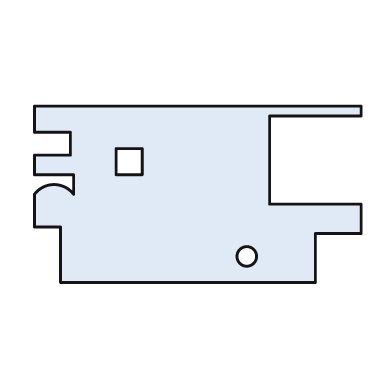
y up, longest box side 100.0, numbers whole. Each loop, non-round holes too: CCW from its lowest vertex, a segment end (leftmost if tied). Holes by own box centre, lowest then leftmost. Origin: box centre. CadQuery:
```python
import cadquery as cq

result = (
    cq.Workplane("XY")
    .moveTo(-42.0, -27.0)
    .lineTo(36.0, -27.0)
    .lineTo(36.0, -12.0)
    .lineTo(50.0, -12.0)
    .lineTo(50.0, -3.0)
    .lineTo(22.0, -3.0)
    .lineTo(22.0, 24.0)
    .lineTo(50.0, 24.0)
    .lineTo(50.0, 27.0)
    .lineTo(-50.0, 27.0)
    .lineTo(-50.0, 19.0)
    .lineTo(-39.0, 19.0)
    .lineTo(-39.0, 12.0)
    .lineTo(-50.0, 12.0)
    .lineTo(-50.0, 6.0)
    .lineTo(-38.0, 6.0)
    .lineTo(-38.0, 0.0)
    .threePointArc((-44.0, 3.0), (-50.0, 0.0))
    .lineTo(-50.0, -10.0)
    .lineTo(-42.0, -10.0)
    .close()
    .moveTo(15.0, -19.0)
    .circle(3.0)
    .moveTo(-25.0, 6.0)
    .lineTo(-17.0, 6.0)
    .lineTo(-17.0, 14.0)
    .lineTo(-25.0, 14.0)
    .close()
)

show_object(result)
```